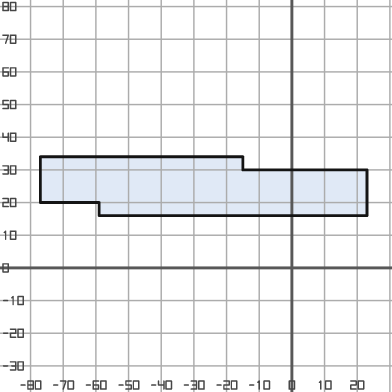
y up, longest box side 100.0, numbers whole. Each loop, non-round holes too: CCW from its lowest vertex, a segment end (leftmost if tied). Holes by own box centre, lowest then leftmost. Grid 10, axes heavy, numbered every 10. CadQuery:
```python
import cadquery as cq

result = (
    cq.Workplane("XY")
    .moveTo(-59.0, 16.0)
    .lineTo(23.0, 16.0)
    .lineTo(23.0, 30.0)
    .lineTo(-15.0, 30.0)
    .lineTo(-15.0, 34.0)
    .lineTo(-77.0, 34.0)
    .lineTo(-77.0, 20.0)
    .lineTo(-59.0, 20.0)
    .close()
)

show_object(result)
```